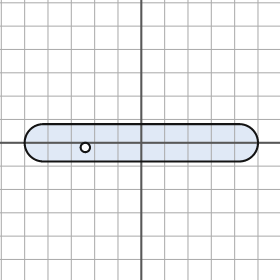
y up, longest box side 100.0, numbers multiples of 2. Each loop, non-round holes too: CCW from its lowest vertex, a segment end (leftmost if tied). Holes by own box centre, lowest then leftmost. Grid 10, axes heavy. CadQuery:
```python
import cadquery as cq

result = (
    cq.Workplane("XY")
    .moveTo(-42.0, -8.0)
    .lineTo(42.0, -8.0)
    .threePointArc((50.0, 0.0), (42.0, 8.0))
    .lineTo(-42.0, 8.0)
    .threePointArc((-50.0, 0.0), (-42.0, -8.0))
    .close()
    .moveTo(-24.0, -2.0)
    .circle(2.0)
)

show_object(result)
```